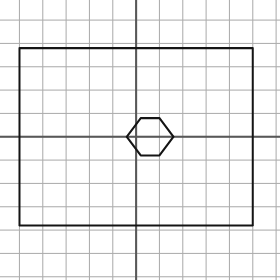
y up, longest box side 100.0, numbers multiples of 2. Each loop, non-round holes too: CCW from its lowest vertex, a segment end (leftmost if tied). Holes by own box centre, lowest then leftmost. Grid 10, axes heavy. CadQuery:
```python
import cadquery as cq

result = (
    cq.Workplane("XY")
    .moveTo(-50.0, -38.0)
    .lineTo(50.0, -38.0)
    .lineTo(50.0, 38.0)
    .lineTo(-50.0, 38.0)
    .close()
    .moveTo(2.0, -8.0)
    .lineTo(10.0, -8.0)
    .lineTo(16.0, 0.0)
    .lineTo(10.0, 8.0)
    .lineTo(2.0, 8.0)
    .lineTo(-4.0, 0.0)
    .close()
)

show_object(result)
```